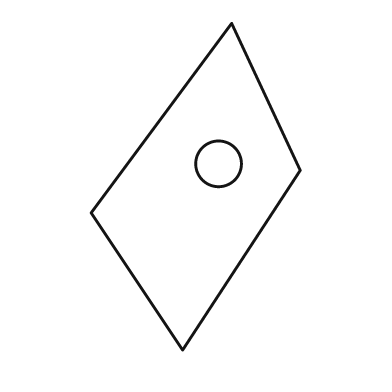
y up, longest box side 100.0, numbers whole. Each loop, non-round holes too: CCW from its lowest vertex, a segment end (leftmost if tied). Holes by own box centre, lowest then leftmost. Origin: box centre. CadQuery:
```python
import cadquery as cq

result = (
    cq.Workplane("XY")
    .moveTo(-4.0, -50.0)
    .lineTo(32.0, 5.0)
    .lineTo(11.0, 50.0)
    .lineTo(-32.0, -8.0)
    .close()
    .moveTo(7.0, 7.0)
    .circle(7.0)
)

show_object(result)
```